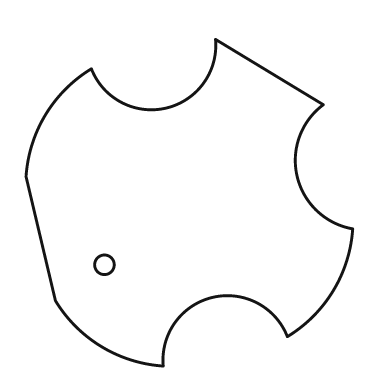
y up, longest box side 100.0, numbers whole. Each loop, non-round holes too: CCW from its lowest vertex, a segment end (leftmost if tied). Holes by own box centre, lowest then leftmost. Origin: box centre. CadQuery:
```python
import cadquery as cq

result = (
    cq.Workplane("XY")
    .moveTo(-8.0, -50.0)
    .threePointArc((7.0, -29.0), (30.0, -41.0))
    .threePointArc((44.0, -27.0), (50.0, -8.0))
    .threePointArc((33.0, 8.0), (41.0, 30.0))
    .lineTo(8.0, 50.0)
    .threePointArc((-7.0, 29.0), (-30.0, 41.0))
    .threePointArc((-44.0, 27.0), (-50.0, 8.0))
    .lineTo(-41.0, -30.0)
    .threePointArc((-27.0, -44.0), (-8.0, -50.0))
    .close()
    .moveTo(-26.0, -19.0)
    .circle(3.0)
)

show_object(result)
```